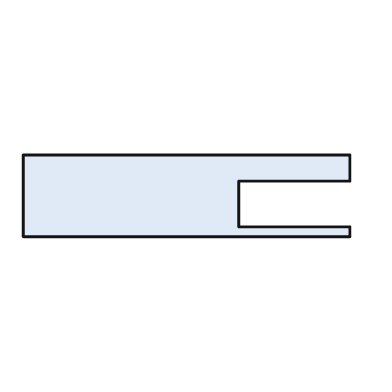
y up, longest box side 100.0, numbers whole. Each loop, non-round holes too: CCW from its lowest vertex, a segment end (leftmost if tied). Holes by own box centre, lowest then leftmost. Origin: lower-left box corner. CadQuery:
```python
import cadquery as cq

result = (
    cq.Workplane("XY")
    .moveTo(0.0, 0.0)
    .lineTo(100.0, 0.0)
    .lineTo(100.0, 3.0)
    .lineTo(66.0, 3.0)
    .lineTo(66.0, 17.0)
    .lineTo(100.0, 17.0)
    .lineTo(100.0, 25.0)
    .lineTo(0.0, 25.0)
    .close()
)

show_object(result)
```